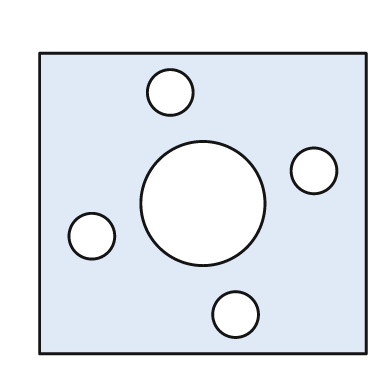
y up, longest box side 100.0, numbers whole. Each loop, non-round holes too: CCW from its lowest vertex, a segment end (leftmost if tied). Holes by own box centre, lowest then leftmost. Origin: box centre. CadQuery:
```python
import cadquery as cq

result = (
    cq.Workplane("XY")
    .moveTo(-50.0, -46.0)
    .lineTo(50.0, -46.0)
    .lineTo(50.0, 46.0)
    .lineTo(-50.0, 46.0)
    .close()
    .moveTo(10.0, -34.0)
    .circle(7.0)
    .moveTo(-34.0, -10.0)
    .circle(7.0)
    .moveTo(0.0, 0.0)
    .circle(19.0)
    .moveTo(34.0, 10.0)
    .circle(7.0)
    .moveTo(-10.0, 34.0)
    .circle(7.0)
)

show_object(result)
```